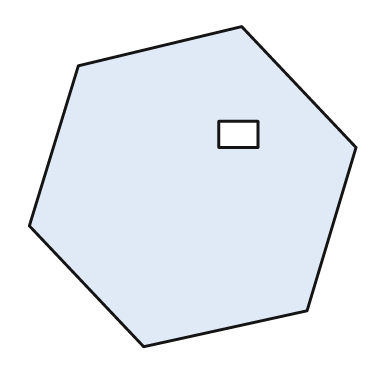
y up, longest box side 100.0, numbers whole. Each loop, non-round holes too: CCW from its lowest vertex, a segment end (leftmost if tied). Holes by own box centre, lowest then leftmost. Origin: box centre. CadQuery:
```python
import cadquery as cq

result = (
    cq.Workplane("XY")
    .moveTo(-15.0, -49.0)
    .lineTo(35.0, -38.0)
    .lineTo(50.0, 12.0)
    .lineTo(15.0, 49.0)
    .lineTo(-35.0, 37.0)
    .lineTo(-50.0, -12.0)
    .close()
    .moveTo(8.0, 12.0)
    .lineTo(20.0, 12.0)
    .lineTo(20.0, 20.0)
    .lineTo(8.0, 20.0)
    .close()
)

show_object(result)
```